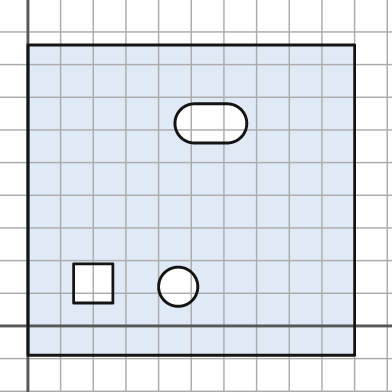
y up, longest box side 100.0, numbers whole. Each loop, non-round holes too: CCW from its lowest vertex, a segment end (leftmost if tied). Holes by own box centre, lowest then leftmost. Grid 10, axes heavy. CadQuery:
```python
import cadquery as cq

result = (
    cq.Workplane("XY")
    .moveTo(0.0, -9.0)
    .lineTo(100.0, -9.0)
    .lineTo(100.0, 86.0)
    .lineTo(0.0, 86.0)
    .close()
    .moveTo(46.0, 12.0)
    .circle(6.0)
    .moveTo(14.0, 7.0)
    .lineTo(26.0, 7.0)
    .lineTo(26.0, 19.0)
    .lineTo(14.0, 19.0)
    .close()
    .moveTo(51.0, 56.0)
    .lineTo(61.0, 56.0)
    .threePointArc((67.0, 62.0), (61.0, 68.0))
    .lineTo(51.0, 68.0)
    .threePointArc((45.0, 62.0), (51.0, 56.0))
    .close()
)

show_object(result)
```